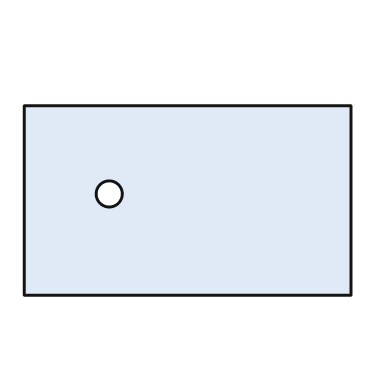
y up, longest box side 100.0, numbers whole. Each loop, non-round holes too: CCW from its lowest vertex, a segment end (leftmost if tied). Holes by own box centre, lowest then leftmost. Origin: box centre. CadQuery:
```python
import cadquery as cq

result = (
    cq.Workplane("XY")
    .moveTo(-50.0, -29.0)
    .lineTo(50.0, -29.0)
    .lineTo(50.0, 29.0)
    .lineTo(-50.0, 29.0)
    .close()
    .moveTo(-24.0, 2.0)
    .circle(4.0)
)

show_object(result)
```